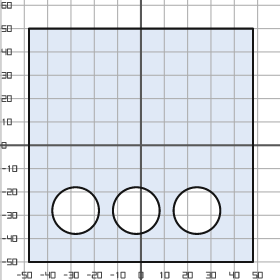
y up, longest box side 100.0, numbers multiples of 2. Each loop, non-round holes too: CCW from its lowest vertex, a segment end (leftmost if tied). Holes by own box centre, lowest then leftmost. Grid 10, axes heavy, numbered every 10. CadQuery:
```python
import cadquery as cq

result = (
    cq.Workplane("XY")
    .moveTo(-48.0, -50.0)
    .lineTo(48.0, -50.0)
    .lineTo(48.0, 50.0)
    .lineTo(-48.0, 50.0)
    .close()
    .moveTo(-28.0, -28.0)
    .circle(10.0)
    .moveTo(-2.0, -28.0)
    .circle(10.0)
    .moveTo(24.0, -28.0)
    .circle(10.0)
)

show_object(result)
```